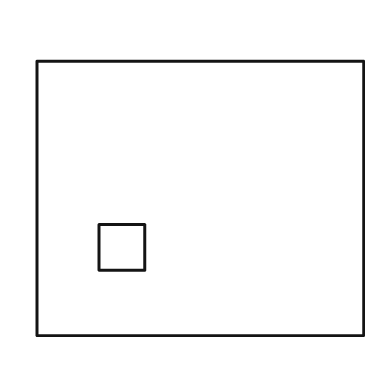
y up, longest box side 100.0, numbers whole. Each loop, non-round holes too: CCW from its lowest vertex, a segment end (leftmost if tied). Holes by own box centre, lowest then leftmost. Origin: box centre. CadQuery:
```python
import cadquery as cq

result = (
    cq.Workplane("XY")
    .moveTo(-50.0, -42.0)
    .lineTo(50.0, -42.0)
    .lineTo(50.0, 42.0)
    .lineTo(-50.0, 42.0)
    .close()
    .moveTo(-31.0, -22.0)
    .lineTo(-17.0, -22.0)
    .lineTo(-17.0, -8.0)
    .lineTo(-31.0, -8.0)
    .close()
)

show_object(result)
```